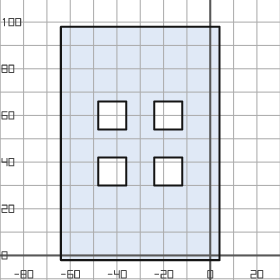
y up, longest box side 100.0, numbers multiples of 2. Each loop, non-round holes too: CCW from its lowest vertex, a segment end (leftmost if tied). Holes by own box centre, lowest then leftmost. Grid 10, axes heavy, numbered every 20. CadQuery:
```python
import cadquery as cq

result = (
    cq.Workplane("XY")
    .moveTo(-64.0, -2.0)
    .lineTo(4.0, -2.0)
    .lineTo(4.0, 98.0)
    .lineTo(-64.0, 98.0)
    .close()
    .moveTo(-48.0, 30.0)
    .lineTo(-36.0, 30.0)
    .lineTo(-36.0, 42.0)
    .lineTo(-48.0, 42.0)
    .close()
    .moveTo(-24.0, 30.0)
    .lineTo(-12.0, 30.0)
    .lineTo(-12.0, 42.0)
    .lineTo(-24.0, 42.0)
    .close()
    .moveTo(-48.0, 54.0)
    .lineTo(-36.0, 54.0)
    .lineTo(-36.0, 66.0)
    .lineTo(-48.0, 66.0)
    .close()
    .moveTo(-24.0, 54.0)
    .lineTo(-12.0, 54.0)
    .lineTo(-12.0, 66.0)
    .lineTo(-24.0, 66.0)
    .close()
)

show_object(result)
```